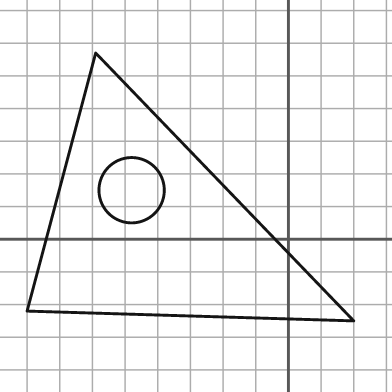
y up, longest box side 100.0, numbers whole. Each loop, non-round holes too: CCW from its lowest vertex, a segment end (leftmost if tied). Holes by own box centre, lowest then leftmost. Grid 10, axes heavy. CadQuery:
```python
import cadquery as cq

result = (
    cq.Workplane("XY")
    .moveTo(20.0, -25.0)
    .lineTo(-59.0, 57.0)
    .lineTo(-80.0, -22.0)
    .close()
    .moveTo(-48.0, 15.0)
    .circle(10.0)
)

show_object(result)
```